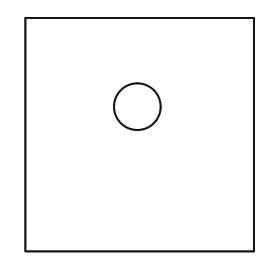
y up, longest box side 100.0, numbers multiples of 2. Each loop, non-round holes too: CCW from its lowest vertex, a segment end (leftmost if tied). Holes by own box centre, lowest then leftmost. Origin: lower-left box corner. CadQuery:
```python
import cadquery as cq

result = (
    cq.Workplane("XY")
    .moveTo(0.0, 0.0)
    .lineTo(98.0, 0.0)
    .lineTo(98.0, 100.0)
    .lineTo(0.0, 100.0)
    .close()
    .moveTo(48.0, 62.0)
    .circle(10.0)
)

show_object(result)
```